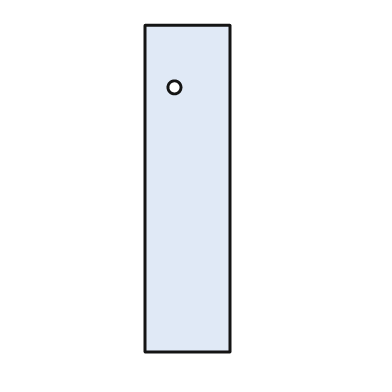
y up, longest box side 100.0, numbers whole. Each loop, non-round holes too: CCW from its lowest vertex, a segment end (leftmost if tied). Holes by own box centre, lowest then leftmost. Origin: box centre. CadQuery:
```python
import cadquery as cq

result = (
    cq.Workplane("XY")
    .moveTo(-13.0, -50.0)
    .lineTo(13.0, -50.0)
    .lineTo(13.0, 50.0)
    .lineTo(-13.0, 50.0)
    .close()
    .moveTo(-4.0, 31.0)
    .circle(2.0)
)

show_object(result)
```